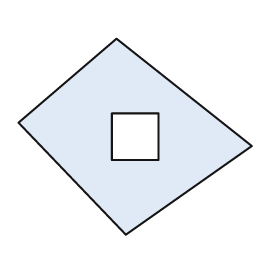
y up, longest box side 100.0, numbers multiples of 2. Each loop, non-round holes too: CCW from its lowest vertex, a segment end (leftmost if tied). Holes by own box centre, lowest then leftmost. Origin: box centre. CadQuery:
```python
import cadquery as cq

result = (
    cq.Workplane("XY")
    .moveTo(-4.0, -42.0)
    .lineTo(50.0, -4.0)
    .lineTo(-8.0, 42.0)
    .lineTo(-50.0, 6.0)
    .close()
    .moveTo(-10.0, -10.0)
    .lineTo(10.0, -10.0)
    .lineTo(10.0, 10.0)
    .lineTo(-10.0, 10.0)
    .close()
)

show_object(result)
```